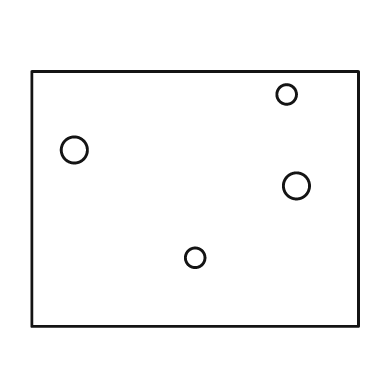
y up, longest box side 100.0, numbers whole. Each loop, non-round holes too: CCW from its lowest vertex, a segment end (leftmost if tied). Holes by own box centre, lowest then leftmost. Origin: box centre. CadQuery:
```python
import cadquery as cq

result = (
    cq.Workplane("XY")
    .moveTo(-50.0, -39.0)
    .lineTo(50.0, -39.0)
    .lineTo(50.0, 39.0)
    .lineTo(-50.0, 39.0)
    .close()
    .moveTo(0.0, -18.0)
    .circle(3.0)
    .moveTo(31.0, 4.0)
    .circle(4.0)
    .moveTo(-37.0, 15.0)
    .circle(4.0)
    .moveTo(28.0, 32.0)
    .circle(3.0)
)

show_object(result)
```